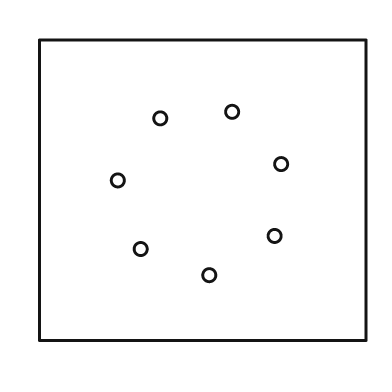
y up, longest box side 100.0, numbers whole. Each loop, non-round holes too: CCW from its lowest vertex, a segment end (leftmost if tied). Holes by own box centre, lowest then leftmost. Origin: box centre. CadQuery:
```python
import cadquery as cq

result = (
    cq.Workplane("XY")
    .moveTo(-50.0, -46.0)
    .lineTo(50.0, -46.0)
    .lineTo(50.0, 46.0)
    .lineTo(-50.0, 46.0)
    .close()
    .moveTo(2.0, -26.0)
    .circle(2.0)
    .moveTo(-19.0, -18.0)
    .circle(2.0)
    .moveTo(22.0, -14.0)
    .circle(2.0)
    .moveTo(-26.0, 3.0)
    .circle(2.0)
    .moveTo(24.0, 8.0)
    .circle(2.0)
    .moveTo(-13.0, 22.0)
    .circle(2.0)
    .moveTo(9.0, 24.0)
    .circle(2.0)
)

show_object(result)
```